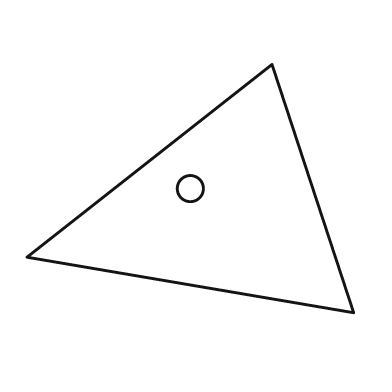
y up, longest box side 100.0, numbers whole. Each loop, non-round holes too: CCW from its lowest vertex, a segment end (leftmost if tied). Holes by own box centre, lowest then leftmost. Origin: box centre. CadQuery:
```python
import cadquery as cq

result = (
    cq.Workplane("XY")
    .moveTo(50.0, -38.0)
    .lineTo(25.0, 38.0)
    .lineTo(-50.0, -21.0)
    .close()
    .moveTo(0.0, 0.0)
    .circle(4.0)
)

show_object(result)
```